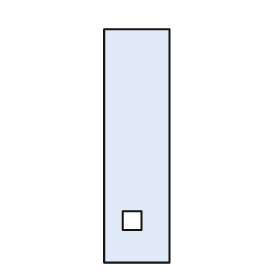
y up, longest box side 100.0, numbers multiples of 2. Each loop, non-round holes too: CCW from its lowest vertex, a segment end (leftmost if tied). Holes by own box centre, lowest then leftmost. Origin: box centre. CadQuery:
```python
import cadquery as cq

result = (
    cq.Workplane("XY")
    .moveTo(-14.0, -50.0)
    .lineTo(14.0, -50.0)
    .lineTo(14.0, 50.0)
    .lineTo(-14.0, 50.0)
    .close()
    .moveTo(-6.0, -36.0)
    .lineTo(2.0, -36.0)
    .lineTo(2.0, -28.0)
    .lineTo(-6.0, -28.0)
    .close()
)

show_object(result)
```